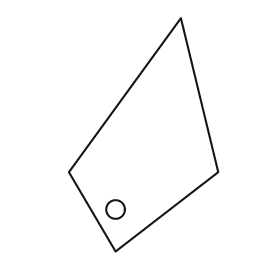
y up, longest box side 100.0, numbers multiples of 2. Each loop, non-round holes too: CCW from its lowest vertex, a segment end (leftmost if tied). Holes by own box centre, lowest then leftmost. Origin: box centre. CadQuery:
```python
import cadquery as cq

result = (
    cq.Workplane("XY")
    .moveTo(-12.0, -50.0)
    .lineTo(32.0, -16.0)
    .lineTo(16.0, 50.0)
    .lineTo(-32.0, -16.0)
    .close()
    .moveTo(-12.0, -32.0)
    .circle(4.0)
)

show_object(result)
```